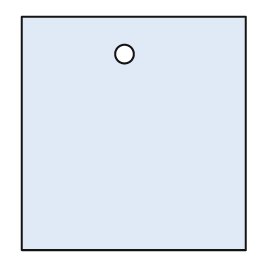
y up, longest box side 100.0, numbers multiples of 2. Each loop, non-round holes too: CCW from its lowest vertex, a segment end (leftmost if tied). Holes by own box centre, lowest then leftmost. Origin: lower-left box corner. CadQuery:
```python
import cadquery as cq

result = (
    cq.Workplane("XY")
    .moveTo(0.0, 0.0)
    .lineTo(96.0, 0.0)
    .lineTo(96.0, 100.0)
    .lineTo(0.0, 100.0)
    .close()
    .moveTo(44.0, 84.0)
    .circle(4.0)
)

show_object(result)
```